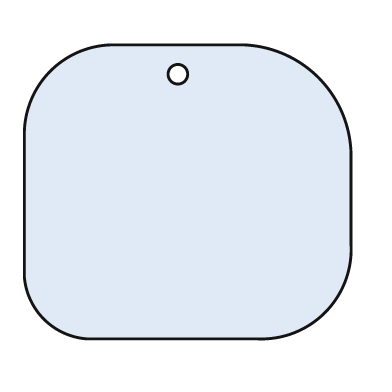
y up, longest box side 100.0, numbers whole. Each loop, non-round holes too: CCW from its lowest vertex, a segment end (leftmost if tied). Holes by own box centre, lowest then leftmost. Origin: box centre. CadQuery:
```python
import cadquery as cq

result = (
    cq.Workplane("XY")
    .moveTo(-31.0, -45.0)
    .lineTo(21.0, -45.0)
    .threePointArc((42.0, -37.0), (50.0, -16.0))
    .lineTo(50.0, 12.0)
    .threePointArc((40.0, 35.0), (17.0, 45.0))
    .lineTo(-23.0, 45.0)
    .threePointArc((-42.0, 37.0), (-50.0, 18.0))
    .lineTo(-50.0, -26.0)
    .threePointArc((-44.0, -39.0), (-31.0, -45.0))
    .close()
    .moveTo(-3.0, 36.0)
    .circle(3.0)
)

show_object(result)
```